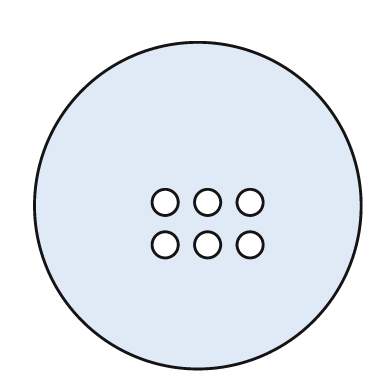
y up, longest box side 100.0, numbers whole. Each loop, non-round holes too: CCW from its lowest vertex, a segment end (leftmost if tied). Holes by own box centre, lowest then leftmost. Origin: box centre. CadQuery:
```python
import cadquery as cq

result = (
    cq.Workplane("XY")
    .moveTo(0.0, 0.0)
    .circle(50.0)
    .moveTo(-10.0, -12.0)
    .circle(4.0)
    .moveTo(3.0, -12.0)
    .circle(4.0)
    .moveTo(16.0, -12.0)
    .circle(4.0)
    .moveTo(-10.0, 1.0)
    .circle(4.0)
    .moveTo(3.0, 1.0)
    .circle(4.0)
    .moveTo(16.0, 1.0)
    .circle(4.0)
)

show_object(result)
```